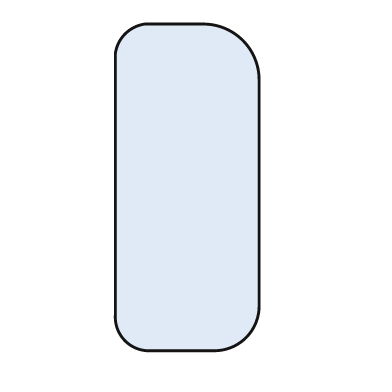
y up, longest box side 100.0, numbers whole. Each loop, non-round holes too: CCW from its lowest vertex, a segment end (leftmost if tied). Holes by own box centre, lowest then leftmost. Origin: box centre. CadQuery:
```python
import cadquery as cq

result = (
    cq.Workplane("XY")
    .moveTo(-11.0, -50.0)
    .lineTo(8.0, -50.0)
    .threePointArc((18.0, -46.0), (22.0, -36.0))
    .lineTo(22.0, 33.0)
    .threePointArc((17.0, 45.0), (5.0, 50.0))
    .lineTo(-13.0, 50.0)
    .threePointArc((-19.0, 47.0), (-22.0, 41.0))
    .lineTo(-22.0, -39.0)
    .threePointArc((-19.0, -47.0), (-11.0, -50.0))
    .close()
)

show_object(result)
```